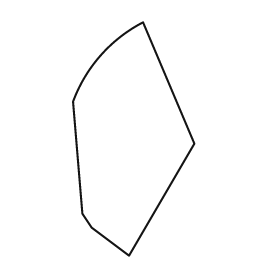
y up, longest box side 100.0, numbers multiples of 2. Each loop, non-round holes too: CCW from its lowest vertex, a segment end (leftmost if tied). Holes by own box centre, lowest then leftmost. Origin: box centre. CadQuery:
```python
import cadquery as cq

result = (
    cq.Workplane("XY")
    .moveTo(-2.0, -50.0)
    .lineTo(26.0, -2.0)
    .lineTo(4.0, 50.0)
    .threePointArc((-14.0, 36.0), (-26.0, 16.0))
    .lineTo(-22.0, -32.0)
    .lineTo(-18.0, -38.0)
    .close()
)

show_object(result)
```